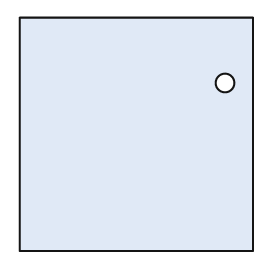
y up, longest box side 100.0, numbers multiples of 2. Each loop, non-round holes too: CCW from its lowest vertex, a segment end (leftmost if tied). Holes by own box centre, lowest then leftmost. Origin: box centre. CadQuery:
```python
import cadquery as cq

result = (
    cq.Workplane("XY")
    .moveTo(-50.0, -50.0)
    .lineTo(50.0, -50.0)
    .lineTo(50.0, 50.0)
    .lineTo(-50.0, 50.0)
    .close()
    .moveTo(38.0, 22.0)
    .circle(4.0)
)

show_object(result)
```